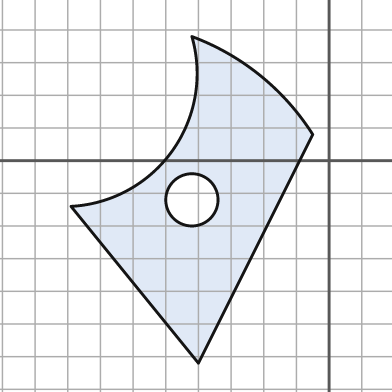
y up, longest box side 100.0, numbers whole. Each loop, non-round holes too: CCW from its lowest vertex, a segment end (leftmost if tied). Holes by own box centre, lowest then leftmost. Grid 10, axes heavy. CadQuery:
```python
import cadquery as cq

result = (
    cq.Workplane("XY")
    .moveTo(-40.0, -62.0)
    .lineTo(-5.0, 8.0)
    .threePointArc((-21.0, 26.0), (-42.0, 38.0))
    .threePointArc((-48.0, 3.0), (-79.0, -14.0))
    .close()
    .moveTo(-42.0, -12.0)
    .circle(8.0)
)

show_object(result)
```